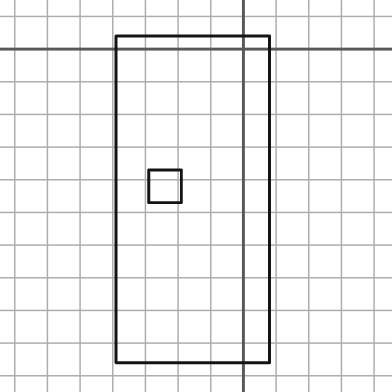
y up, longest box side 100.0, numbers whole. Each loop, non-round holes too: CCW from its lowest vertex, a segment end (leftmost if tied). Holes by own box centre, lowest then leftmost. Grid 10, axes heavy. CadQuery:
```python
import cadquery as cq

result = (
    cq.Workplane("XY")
    .moveTo(-39.0, -96.0)
    .lineTo(8.0, -96.0)
    .lineTo(8.0, 4.0)
    .lineTo(-39.0, 4.0)
    .close()
    .moveTo(-29.0, -47.0)
    .lineTo(-19.0, -47.0)
    .lineTo(-19.0, -37.0)
    .lineTo(-29.0, -37.0)
    .close()
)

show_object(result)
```